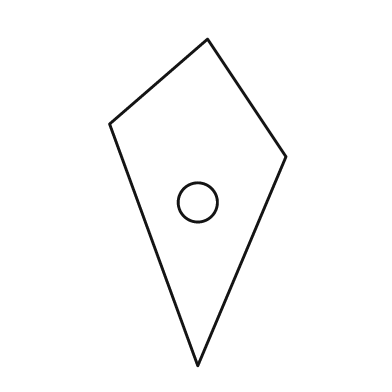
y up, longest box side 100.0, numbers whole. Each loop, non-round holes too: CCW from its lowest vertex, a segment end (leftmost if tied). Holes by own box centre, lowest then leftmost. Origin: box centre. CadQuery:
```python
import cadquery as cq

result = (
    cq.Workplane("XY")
    .moveTo(0.0, -50.0)
    .lineTo(27.0, 14.0)
    .lineTo(3.0, 50.0)
    .lineTo(-27.0, 24.0)
    .close()
    .moveTo(0.0, 0.0)
    .circle(6.0)
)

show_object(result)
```